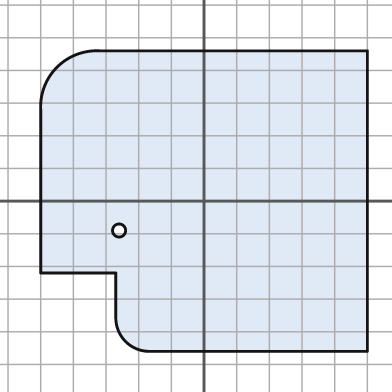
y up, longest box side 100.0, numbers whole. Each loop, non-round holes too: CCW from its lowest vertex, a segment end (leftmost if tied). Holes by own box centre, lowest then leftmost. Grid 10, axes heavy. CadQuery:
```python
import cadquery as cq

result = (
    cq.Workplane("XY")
    .moveTo(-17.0, -46.0)
    .lineTo(50.0, -46.0)
    .lineTo(50.0, 46.0)
    .lineTo(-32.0, 46.0)
    .threePointArc((-45.0, 41.0), (-50.0, 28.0))
    .lineTo(-50.0, -22.0)
    .lineTo(-27.0, -22.0)
    .lineTo(-27.0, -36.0)
    .threePointArc((-24.0, -43.0), (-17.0, -46.0))
    .close()
    .moveTo(-26.0, -9.0)
    .circle(2.0)
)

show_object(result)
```